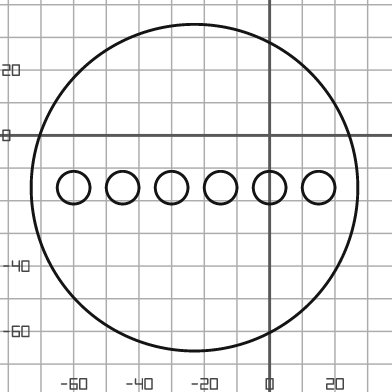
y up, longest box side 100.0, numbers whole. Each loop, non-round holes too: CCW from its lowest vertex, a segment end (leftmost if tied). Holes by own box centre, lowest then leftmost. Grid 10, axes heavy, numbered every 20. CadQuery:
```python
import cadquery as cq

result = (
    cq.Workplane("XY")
    .moveTo(-23.0, -16.0)
    .circle(50.0)
    .moveTo(-60.0, -16.0)
    .circle(5.0)
    .moveTo(-45.0, -16.0)
    .circle(5.0)
    .moveTo(-30.0, -16.0)
    .circle(5.0)
    .moveTo(-15.0, -16.0)
    .circle(5.0)
    .moveTo(0.0, -16.0)
    .circle(5.0)
    .moveTo(15.0, -16.0)
    .circle(5.0)
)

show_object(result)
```